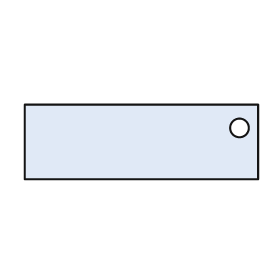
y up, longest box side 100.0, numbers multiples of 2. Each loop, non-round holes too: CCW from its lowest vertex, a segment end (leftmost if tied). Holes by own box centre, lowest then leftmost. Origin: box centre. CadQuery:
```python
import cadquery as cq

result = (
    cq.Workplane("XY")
    .moveTo(-50.0, -16.0)
    .lineTo(50.0, -16.0)
    .lineTo(50.0, 16.0)
    .lineTo(-50.0, 16.0)
    .close()
    .moveTo(42.0, 6.0)
    .circle(4.0)
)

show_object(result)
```